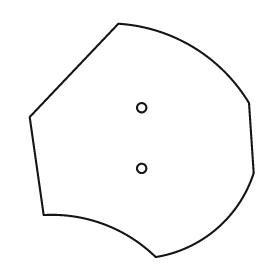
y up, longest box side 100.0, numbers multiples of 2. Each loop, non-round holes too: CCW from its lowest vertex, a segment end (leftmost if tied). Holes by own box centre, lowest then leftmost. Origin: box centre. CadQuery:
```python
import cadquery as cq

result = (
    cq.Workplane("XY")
    .moveTo(6.0, -50.0)
    .threePointArc((32.0, -38.0), (48.0, -14.0))
    .lineTo(46.0, 16.0)
    .threePointArc((22.0, 40.0), (-10.0, 50.0))
    .lineTo(-48.0, 10.0)
    .lineTo(-42.0, -32.0)
    .threePointArc((-16.0, -36.0), (6.0, -50.0))
    .close()
    .moveTo(0.0, -12.0)
    .circle(2.0)
    .moveTo(0.0, 14.0)
    .circle(2.0)
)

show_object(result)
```